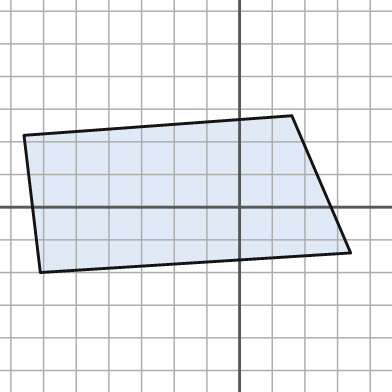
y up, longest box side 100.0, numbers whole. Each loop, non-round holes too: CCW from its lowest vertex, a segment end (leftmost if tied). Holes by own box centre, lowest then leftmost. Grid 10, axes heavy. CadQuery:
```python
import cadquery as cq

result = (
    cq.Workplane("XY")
    .moveTo(-61.0, -20.0)
    .lineTo(34.0, -14.0)
    .lineTo(16.0, 28.0)
    .lineTo(-66.0, 22.0)
    .close()
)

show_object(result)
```